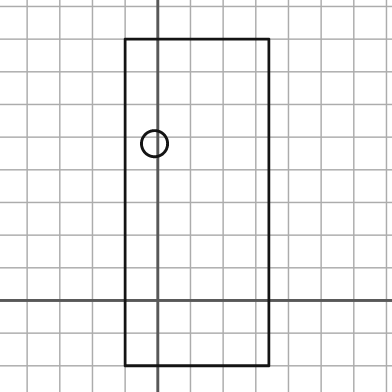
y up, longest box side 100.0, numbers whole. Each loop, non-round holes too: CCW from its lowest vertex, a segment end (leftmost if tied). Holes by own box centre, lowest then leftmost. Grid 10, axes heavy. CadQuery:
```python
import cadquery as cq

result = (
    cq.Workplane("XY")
    .moveTo(-10.0, -20.0)
    .lineTo(34.0, -20.0)
    .lineTo(34.0, 80.0)
    .lineTo(-10.0, 80.0)
    .close()
    .moveTo(-1.0, 48.0)
    .circle(4.0)
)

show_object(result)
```